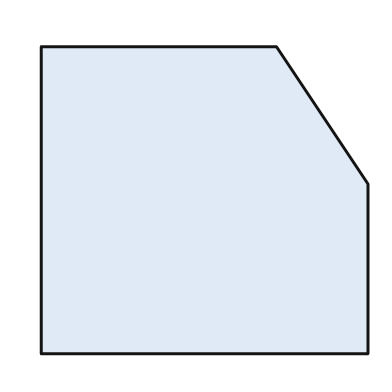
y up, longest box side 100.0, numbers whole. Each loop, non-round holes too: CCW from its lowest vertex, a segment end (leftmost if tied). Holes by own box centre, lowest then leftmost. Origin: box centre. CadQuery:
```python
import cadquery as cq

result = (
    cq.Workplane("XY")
    .moveTo(-50.0, -47.0)
    .lineTo(50.0, -47.0)
    .lineTo(50.0, 5.0)
    .lineTo(22.0, 47.0)
    .lineTo(-50.0, 47.0)
    .close()
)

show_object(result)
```